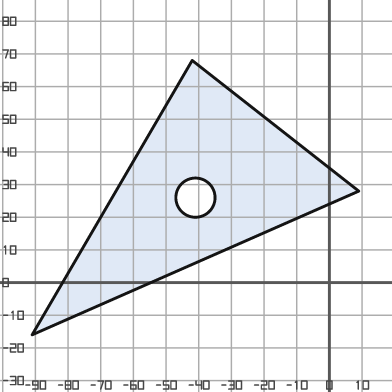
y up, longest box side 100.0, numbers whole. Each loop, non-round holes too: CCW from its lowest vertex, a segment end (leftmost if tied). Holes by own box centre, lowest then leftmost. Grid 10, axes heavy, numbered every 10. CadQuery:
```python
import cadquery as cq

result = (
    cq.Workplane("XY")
    .moveTo(-91.0, -16.0)
    .lineTo(9.0, 28.0)
    .lineTo(-42.0, 68.0)
    .close()
    .moveTo(-41.0, 26.0)
    .circle(6.0)
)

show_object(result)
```